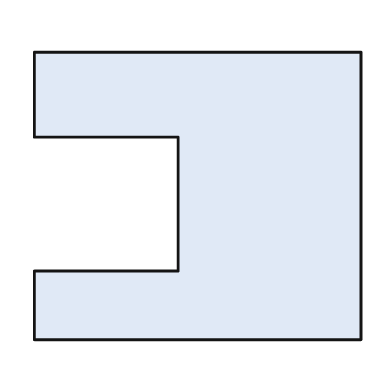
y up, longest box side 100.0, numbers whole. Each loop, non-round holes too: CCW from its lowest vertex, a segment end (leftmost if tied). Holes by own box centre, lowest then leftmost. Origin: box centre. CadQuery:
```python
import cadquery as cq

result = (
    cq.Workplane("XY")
    .moveTo(-50.0, -44.0)
    .lineTo(50.0, -44.0)
    .lineTo(50.0, 44.0)
    .lineTo(-50.0, 44.0)
    .lineTo(-50.0, 18.0)
    .lineTo(-6.0, 18.0)
    .lineTo(-6.0, -23.0)
    .lineTo(-50.0, -23.0)
    .close()
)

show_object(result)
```